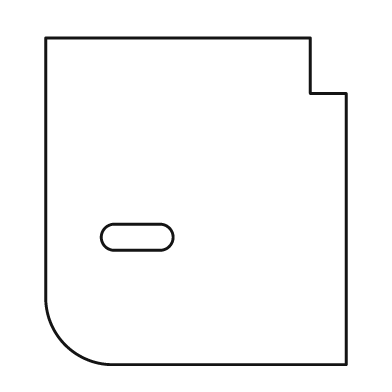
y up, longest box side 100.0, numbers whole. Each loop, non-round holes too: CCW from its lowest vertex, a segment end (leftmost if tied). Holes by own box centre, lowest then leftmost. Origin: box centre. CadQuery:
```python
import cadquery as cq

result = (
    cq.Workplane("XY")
    .moveTo(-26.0, -50.0)
    .lineTo(46.0, -50.0)
    .lineTo(46.0, 33.0)
    .lineTo(35.0, 33.0)
    .lineTo(35.0, 50.0)
    .lineTo(-46.0, 50.0)
    .lineTo(-46.0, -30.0)
    .threePointArc((-40.0, -44.0), (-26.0, -50.0))
    .close()
    .moveTo(-25.0, -15.0)
    .lineTo(-11.0, -15.0)
    .threePointArc((-7.0, -11.0), (-11.0, -7.0))
    .lineTo(-25.0, -7.0)
    .threePointArc((-29.0, -11.0), (-25.0, -15.0))
    .close()
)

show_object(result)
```